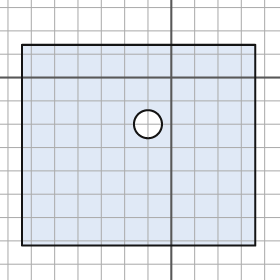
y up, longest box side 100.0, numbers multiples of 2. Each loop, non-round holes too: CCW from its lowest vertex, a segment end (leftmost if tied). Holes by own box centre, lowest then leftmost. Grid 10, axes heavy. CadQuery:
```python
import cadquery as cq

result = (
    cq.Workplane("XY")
    .moveTo(-64.0, -72.0)
    .lineTo(36.0, -72.0)
    .lineTo(36.0, 14.0)
    .lineTo(-64.0, 14.0)
    .close()
    .moveTo(-10.0, -20.0)
    .circle(6.0)
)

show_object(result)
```